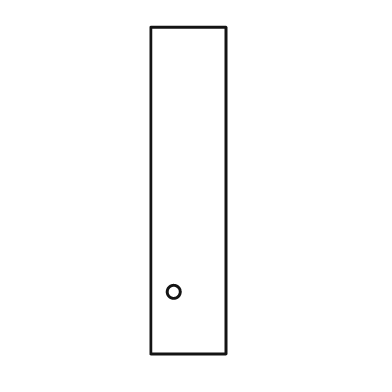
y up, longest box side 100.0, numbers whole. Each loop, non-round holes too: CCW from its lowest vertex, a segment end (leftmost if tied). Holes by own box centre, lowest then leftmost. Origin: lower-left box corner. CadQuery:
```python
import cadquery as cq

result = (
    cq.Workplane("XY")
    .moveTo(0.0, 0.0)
    .lineTo(23.0, 0.0)
    .lineTo(23.0, 100.0)
    .lineTo(0.0, 100.0)
    .close()
    .moveTo(7.0, 19.0)
    .circle(2.0)
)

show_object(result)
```